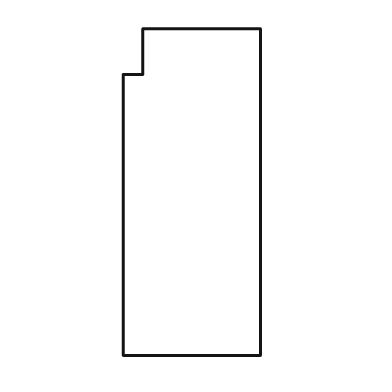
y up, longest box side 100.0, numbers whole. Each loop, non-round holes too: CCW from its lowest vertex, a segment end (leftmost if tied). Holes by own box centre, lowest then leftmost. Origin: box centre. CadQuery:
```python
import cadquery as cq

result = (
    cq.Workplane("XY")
    .moveTo(-21.0, -50.0)
    .lineTo(21.0, -50.0)
    .lineTo(21.0, 50.0)
    .lineTo(-15.0, 50.0)
    .lineTo(-15.0, 36.0)
    .lineTo(-21.0, 36.0)
    .close()
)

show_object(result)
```